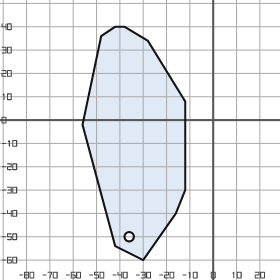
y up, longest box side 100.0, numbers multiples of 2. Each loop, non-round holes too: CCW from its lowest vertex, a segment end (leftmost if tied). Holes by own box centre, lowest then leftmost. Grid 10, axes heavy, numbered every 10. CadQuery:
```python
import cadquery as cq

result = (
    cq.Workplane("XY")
    .moveTo(-30.0, -60.0)
    .lineTo(-16.0, -40.0)
    .lineTo(-12.0, -30.0)
    .lineTo(-12.0, 8.0)
    .lineTo(-28.0, 34.0)
    .lineTo(-38.0, 40.0)
    .lineTo(-42.0, 40.0)
    .lineTo(-48.0, 36.0)
    .lineTo(-56.0, -2.0)
    .lineTo(-42.0, -54.0)
    .close()
    .moveTo(-36.0, -50.0)
    .circle(2.0)
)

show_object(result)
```